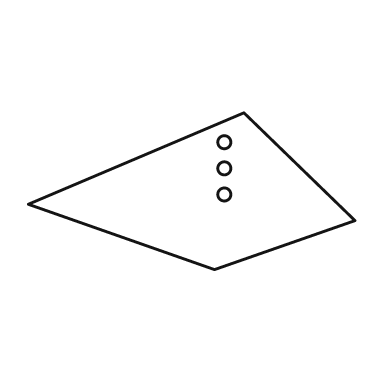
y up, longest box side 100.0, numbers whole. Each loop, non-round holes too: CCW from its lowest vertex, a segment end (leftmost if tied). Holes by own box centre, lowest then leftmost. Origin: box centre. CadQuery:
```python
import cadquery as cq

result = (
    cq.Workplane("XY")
    .moveTo(7.0, -24.0)
    .lineTo(50.0, -9.0)
    .lineTo(16.0, 24.0)
    .lineTo(-50.0, -4.0)
    .close()
    .moveTo(10.0, -1.0)
    .circle(2.0)
    .moveTo(10.0, 7.0)
    .circle(2.0)
    .moveTo(10.0, 15.0)
    .circle(2.0)
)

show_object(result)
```